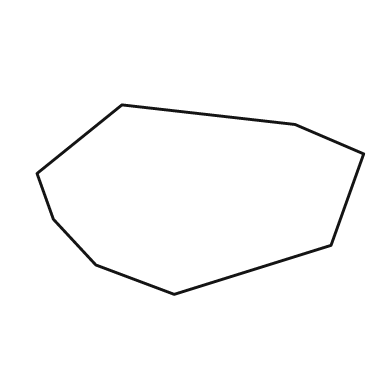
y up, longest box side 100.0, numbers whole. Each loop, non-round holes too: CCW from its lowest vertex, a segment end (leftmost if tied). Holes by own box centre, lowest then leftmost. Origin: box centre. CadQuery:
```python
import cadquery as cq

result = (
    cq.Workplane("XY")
    .moveTo(-8.0, -29.0)
    .lineTo(40.0, -14.0)
    .lineTo(50.0, 14.0)
    .lineTo(29.0, 23.0)
    .lineTo(-24.0, 29.0)
    .lineTo(-50.0, 8.0)
    .lineTo(-45.0, -6.0)
    .lineTo(-32.0, -20.0)
    .close()
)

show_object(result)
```